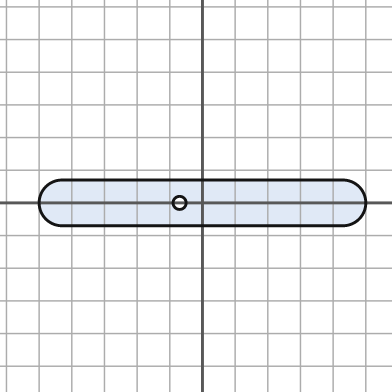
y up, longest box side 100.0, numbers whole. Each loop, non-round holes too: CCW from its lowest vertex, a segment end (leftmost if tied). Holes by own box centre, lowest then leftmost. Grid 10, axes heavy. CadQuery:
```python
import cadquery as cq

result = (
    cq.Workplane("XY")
    .moveTo(-43.0, -7.0)
    .lineTo(43.0, -7.0)
    .threePointArc((50.0, 0.0), (43.0, 7.0))
    .lineTo(-43.0, 7.0)
    .threePointArc((-50.0, 0.0), (-43.0, -7.0))
    .close()
    .moveTo(-7.0, 0.0)
    .circle(2.0)
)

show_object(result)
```